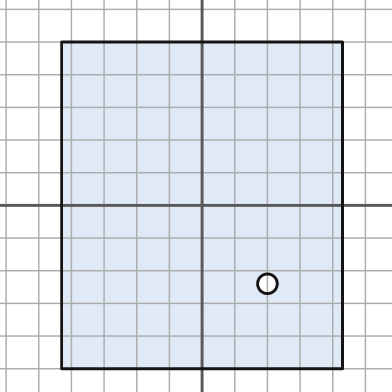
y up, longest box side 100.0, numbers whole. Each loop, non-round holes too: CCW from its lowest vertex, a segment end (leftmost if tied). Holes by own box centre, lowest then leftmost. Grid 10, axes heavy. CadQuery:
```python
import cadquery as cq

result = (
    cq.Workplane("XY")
    .moveTo(-43.0, -50.0)
    .lineTo(43.0, -50.0)
    .lineTo(43.0, 50.0)
    .lineTo(-43.0, 50.0)
    .close()
    .moveTo(20.0, -24.0)
    .circle(3.0)
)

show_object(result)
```